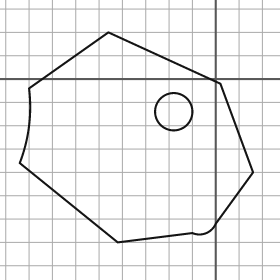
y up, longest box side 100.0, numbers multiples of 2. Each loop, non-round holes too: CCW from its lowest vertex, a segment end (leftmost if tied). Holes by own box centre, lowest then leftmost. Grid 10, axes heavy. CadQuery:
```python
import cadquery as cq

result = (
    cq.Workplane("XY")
    .moveTo(-42.0, -70.0)
    .lineTo(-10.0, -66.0)
    .threePointArc((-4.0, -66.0), (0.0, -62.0))
    .lineTo(16.0, -40.0)
    .lineTo(2.0, -2.0)
    .lineTo(-46.0, 20.0)
    .lineTo(-80.0, -4.0)
    .threePointArc((-80.0, -20.0), (-84.0, -36.0))
    .close()
    .moveTo(-18.0, -14.0)
    .circle(8.0)
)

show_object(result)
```